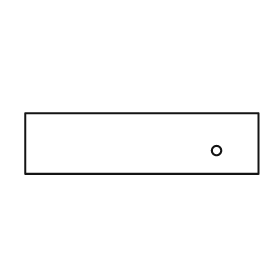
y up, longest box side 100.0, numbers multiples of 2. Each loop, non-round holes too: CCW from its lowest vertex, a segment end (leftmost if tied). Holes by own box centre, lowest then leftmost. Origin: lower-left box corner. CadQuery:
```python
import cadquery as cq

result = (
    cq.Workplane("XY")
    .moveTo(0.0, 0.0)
    .lineTo(100.0, 0.0)
    .lineTo(100.0, 26.0)
    .lineTo(0.0, 26.0)
    .close()
    .moveTo(82.0, 10.0)
    .circle(2.0)
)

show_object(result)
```